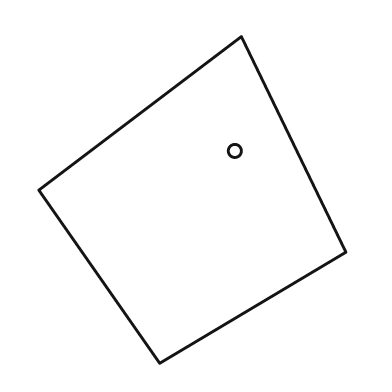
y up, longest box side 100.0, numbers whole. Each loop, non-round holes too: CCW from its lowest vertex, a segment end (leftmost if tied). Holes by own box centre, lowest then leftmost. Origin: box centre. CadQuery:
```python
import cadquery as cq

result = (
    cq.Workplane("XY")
    .moveTo(-10.0, -50.0)
    .lineTo(47.0, -16.0)
    .lineTo(15.0, 50.0)
    .lineTo(-47.0, 3.0)
    .close()
    .moveTo(13.0, 15.0)
    .circle(2.0)
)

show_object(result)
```